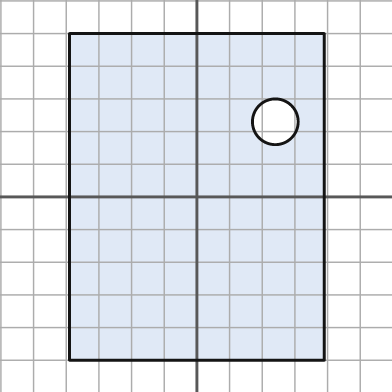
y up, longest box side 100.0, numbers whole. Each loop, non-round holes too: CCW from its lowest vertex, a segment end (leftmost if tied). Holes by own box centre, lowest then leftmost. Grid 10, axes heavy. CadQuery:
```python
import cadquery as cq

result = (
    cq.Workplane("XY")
    .moveTo(-39.0, -50.0)
    .lineTo(39.0, -50.0)
    .lineTo(39.0, 50.0)
    .lineTo(-39.0, 50.0)
    .close()
    .moveTo(24.0, 23.0)
    .circle(7.0)
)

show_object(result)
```